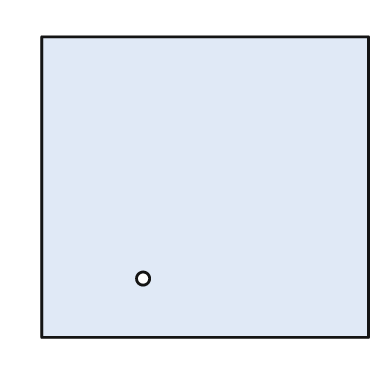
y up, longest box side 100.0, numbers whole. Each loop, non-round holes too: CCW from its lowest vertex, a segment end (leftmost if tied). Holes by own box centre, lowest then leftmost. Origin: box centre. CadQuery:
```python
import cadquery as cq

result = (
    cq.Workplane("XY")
    .moveTo(-50.0, -46.0)
    .lineTo(50.0, -46.0)
    .lineTo(50.0, 46.0)
    .lineTo(-50.0, 46.0)
    .close()
    .moveTo(-19.0, -28.0)
    .circle(2.0)
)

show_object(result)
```